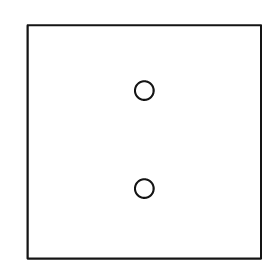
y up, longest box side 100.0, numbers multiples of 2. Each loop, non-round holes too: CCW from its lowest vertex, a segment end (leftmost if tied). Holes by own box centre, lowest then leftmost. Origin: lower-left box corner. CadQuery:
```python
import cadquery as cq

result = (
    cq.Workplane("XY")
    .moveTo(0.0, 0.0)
    .lineTo(100.0, 0.0)
    .lineTo(100.0, 100.0)
    .lineTo(0.0, 100.0)
    .close()
    .moveTo(50.0, 30.0)
    .circle(4.0)
    .moveTo(50.0, 72.0)
    .circle(4.0)
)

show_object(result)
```